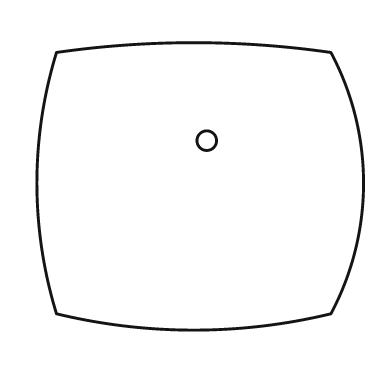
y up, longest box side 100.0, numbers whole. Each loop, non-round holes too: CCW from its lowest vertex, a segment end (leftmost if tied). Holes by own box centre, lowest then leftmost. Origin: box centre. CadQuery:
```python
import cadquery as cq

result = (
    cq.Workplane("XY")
    .moveTo(-44.0, -39.0)
    .threePointArc((-2.0, -44.0), (40.0, -39.0))
    .threePointArc((50.0, 1.0), (40.0, 41.0))
    .threePointArc((-2.0, 44.0), (-44.0, 41.0))
    .threePointArc((-50.0, 1.0), (-44.0, -39.0))
    .close()
    .moveTo(2.0, 14.0)
    .circle(3.0)
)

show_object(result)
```